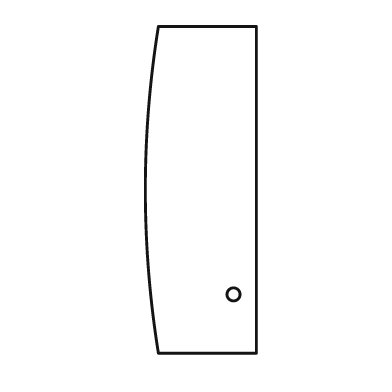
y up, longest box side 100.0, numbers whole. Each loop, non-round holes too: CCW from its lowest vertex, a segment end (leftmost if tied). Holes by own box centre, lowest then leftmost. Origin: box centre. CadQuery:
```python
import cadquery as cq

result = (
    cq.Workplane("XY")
    .moveTo(-13.0, -50.0)
    .lineTo(17.0, -50.0)
    .lineTo(17.0, 50.0)
    .lineTo(-13.0, 50.0)
    .threePointArc((-17.0, 0.0), (-13.0, -50.0))
    .close()
    .moveTo(10.0, -32.0)
    .circle(2.0)
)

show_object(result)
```